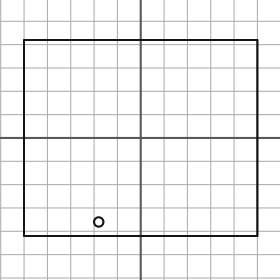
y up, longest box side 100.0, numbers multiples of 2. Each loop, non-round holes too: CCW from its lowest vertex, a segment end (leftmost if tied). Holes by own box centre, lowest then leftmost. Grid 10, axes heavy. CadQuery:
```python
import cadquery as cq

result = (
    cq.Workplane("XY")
    .moveTo(-50.0, -42.0)
    .lineTo(50.0, -42.0)
    .lineTo(50.0, 42.0)
    .lineTo(-50.0, 42.0)
    .close()
    .moveTo(-18.0, -36.0)
    .circle(2.0)
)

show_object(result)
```